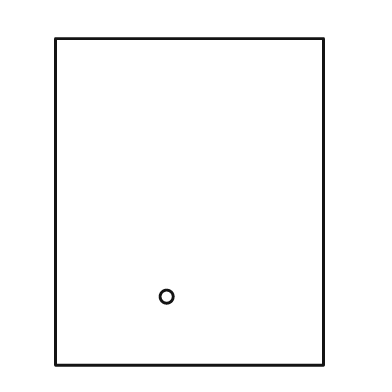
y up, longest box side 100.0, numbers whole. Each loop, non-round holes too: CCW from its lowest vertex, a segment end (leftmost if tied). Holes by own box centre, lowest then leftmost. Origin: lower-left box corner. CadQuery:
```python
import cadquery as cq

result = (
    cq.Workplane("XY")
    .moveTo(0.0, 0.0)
    .lineTo(82.0, 0.0)
    .lineTo(82.0, 100.0)
    .lineTo(0.0, 100.0)
    .close()
    .moveTo(34.0, 21.0)
    .circle(2.0)
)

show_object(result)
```